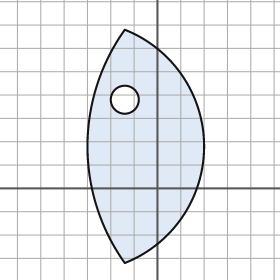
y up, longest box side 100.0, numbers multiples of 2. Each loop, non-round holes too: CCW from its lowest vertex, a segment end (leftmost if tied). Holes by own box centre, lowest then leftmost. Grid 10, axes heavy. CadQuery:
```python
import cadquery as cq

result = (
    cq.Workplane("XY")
    .moveTo(-14.0, -32.0)
    .threePointArc((20.0, 18.0), (-14.0, 68.0))
    .threePointArc((-30.0, 18.0), (-14.0, -32.0))
    .close()
    .moveTo(-14.0, 38.0)
    .circle(6.0)
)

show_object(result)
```